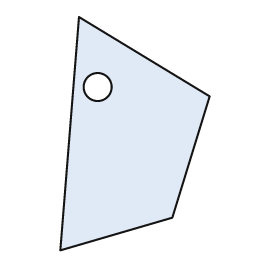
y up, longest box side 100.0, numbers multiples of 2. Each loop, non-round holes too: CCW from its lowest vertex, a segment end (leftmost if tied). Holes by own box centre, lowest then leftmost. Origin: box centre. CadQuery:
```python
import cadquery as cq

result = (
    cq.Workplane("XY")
    .moveTo(-32.0, -50.0)
    .lineTo(16.0, -36.0)
    .lineTo(32.0, 16.0)
    .lineTo(-24.0, 50.0)
    .close()
    .moveTo(-16.0, 20.0)
    .circle(6.0)
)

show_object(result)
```